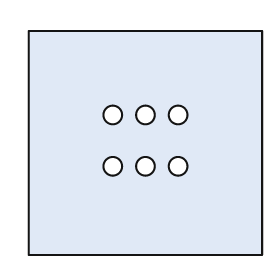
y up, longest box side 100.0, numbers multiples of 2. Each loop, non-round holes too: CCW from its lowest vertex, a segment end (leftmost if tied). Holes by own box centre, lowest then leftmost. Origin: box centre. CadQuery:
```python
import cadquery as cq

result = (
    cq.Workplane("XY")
    .moveTo(-50.0, -48.0)
    .lineTo(50.0, -48.0)
    .lineTo(50.0, 48.0)
    .lineTo(-50.0, 48.0)
    .close()
    .moveTo(-14.0, -10.0)
    .circle(4.0)
    .moveTo(0.0, -10.0)
    .circle(4.0)
    .moveTo(14.0, -10.0)
    .circle(4.0)
    .moveTo(-14.0, 12.0)
    .circle(4.0)
    .moveTo(0.0, 12.0)
    .circle(4.0)
    .moveTo(14.0, 12.0)
    .circle(4.0)
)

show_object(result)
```